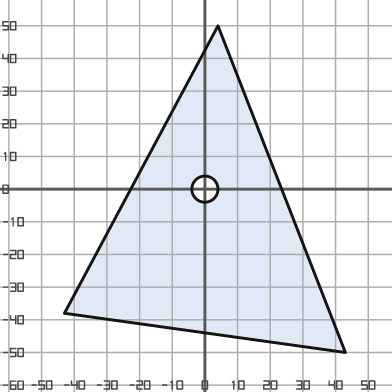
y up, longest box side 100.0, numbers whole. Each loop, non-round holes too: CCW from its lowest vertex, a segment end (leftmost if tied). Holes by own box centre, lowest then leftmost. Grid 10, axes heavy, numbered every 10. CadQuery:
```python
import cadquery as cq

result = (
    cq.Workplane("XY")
    .moveTo(43.0, -50.0)
    .lineTo(4.0, 50.0)
    .lineTo(-43.0, -38.0)
    .close()
    .moveTo(0.0, 0.0)
    .circle(4.0)
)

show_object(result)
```